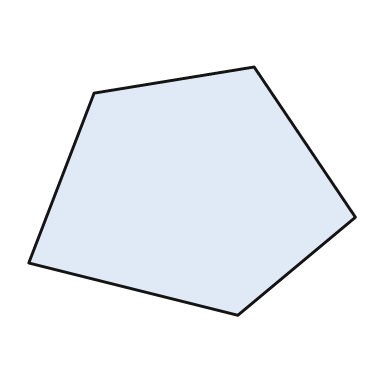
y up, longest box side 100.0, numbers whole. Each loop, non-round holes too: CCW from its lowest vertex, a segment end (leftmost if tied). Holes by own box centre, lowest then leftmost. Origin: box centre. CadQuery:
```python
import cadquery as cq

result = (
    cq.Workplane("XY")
    .moveTo(14.0, -38.0)
    .lineTo(50.0, -8.0)
    .lineTo(19.0, 38.0)
    .lineTo(-30.0, 30.0)
    .lineTo(-50.0, -22.0)
    .close()
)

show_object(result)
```